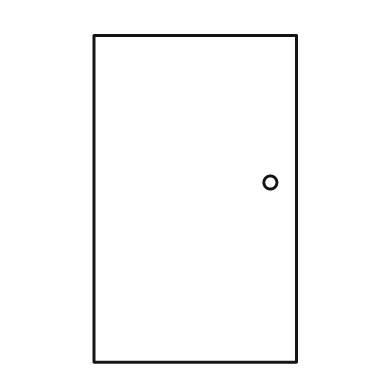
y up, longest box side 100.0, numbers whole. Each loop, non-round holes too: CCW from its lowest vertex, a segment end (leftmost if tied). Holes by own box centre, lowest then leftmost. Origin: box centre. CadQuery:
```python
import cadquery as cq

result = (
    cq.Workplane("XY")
    .moveTo(-31.0, -50.0)
    .lineTo(31.0, -50.0)
    .lineTo(31.0, 50.0)
    .lineTo(-31.0, 50.0)
    .close()
    .moveTo(23.0, 5.0)
    .circle(2.0)
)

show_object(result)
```